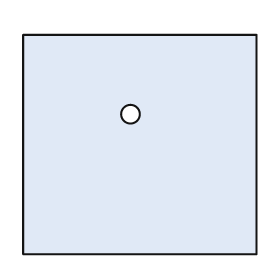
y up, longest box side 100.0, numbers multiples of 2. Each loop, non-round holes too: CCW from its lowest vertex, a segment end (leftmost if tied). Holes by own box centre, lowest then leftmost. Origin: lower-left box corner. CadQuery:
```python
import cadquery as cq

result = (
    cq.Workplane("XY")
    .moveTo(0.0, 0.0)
    .lineTo(100.0, 0.0)
    .lineTo(100.0, 94.0)
    .lineTo(0.0, 94.0)
    .close()
    .moveTo(46.0, 60.0)
    .circle(4.0)
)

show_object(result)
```